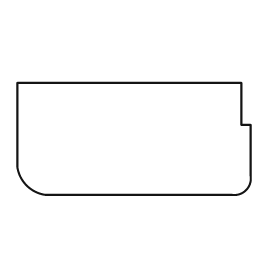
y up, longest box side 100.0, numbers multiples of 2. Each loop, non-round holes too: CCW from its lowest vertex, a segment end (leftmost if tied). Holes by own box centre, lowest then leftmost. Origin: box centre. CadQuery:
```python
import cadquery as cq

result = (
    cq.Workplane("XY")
    .moveTo(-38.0, -24.0)
    .lineTo(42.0, -24.0)
    .threePointArc((48.0, -22.0), (50.0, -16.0))
    .lineTo(50.0, 6.0)
    .lineTo(46.0, 6.0)
    .lineTo(46.0, 24.0)
    .lineTo(-50.0, 24.0)
    .lineTo(-50.0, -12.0)
    .threePointArc((-46.0, -20.0), (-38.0, -24.0))
    .close()
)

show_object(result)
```